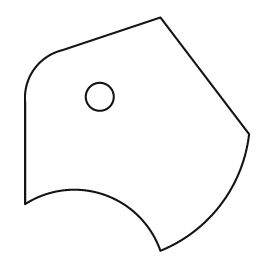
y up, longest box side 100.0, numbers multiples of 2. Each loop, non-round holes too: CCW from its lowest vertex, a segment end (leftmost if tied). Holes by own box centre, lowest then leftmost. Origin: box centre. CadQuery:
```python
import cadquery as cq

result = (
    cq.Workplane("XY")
    .moveTo(10.0, -50.0)
    .threePointArc((36.0, -30.0), (48.0, 0.0))
    .lineTo(10.0, 50.0)
    .lineTo(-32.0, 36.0)
    .threePointArc((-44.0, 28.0), (-48.0, 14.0))
    .lineTo(-48.0, -30.0)
    .threePointArc((-14.0, -26.0), (10.0, -50.0))
    .close()
    .moveTo(-16.0, 16.0)
    .circle(6.0)
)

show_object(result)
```